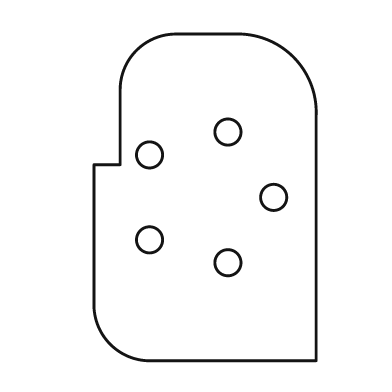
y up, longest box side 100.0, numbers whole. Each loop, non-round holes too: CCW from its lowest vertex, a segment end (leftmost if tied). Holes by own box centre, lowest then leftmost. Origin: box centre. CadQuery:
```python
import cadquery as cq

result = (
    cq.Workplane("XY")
    .moveTo(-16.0, -50.0)
    .lineTo(34.0, -50.0)
    .lineTo(34.0, 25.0)
    .threePointArc((27.0, 43.0), (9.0, 50.0))
    .lineTo(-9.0, 50.0)
    .threePointArc((-21.0, 45.0), (-26.0, 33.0))
    .lineTo(-26.0, 10.0)
    .lineTo(-34.0, 10.0)
    .lineTo(-34.0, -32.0)
    .threePointArc((-29.0, -45.0), (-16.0, -50.0))
    .close()
    .moveTo(7.0, -20.0)
    .circle(4.0)
    .moveTo(-17.0, -13.0)
    .circle(4.0)
    .moveTo(21.0, 0.0)
    .circle(4.0)
    .moveTo(-17.0, 13.0)
    .circle(4.0)
    .moveTo(7.0, 20.0)
    .circle(4.0)
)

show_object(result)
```